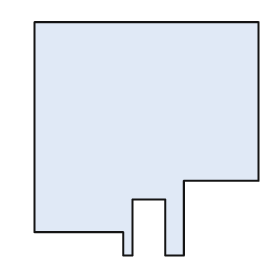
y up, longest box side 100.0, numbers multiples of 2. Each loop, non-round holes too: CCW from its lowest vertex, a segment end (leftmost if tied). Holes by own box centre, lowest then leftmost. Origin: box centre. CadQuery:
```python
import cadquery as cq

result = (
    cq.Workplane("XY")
    .moveTo(-10.0, -50.0)
    .lineTo(-6.0, -50.0)
    .lineTo(-6.0, -26.0)
    .lineTo(8.0, -26.0)
    .lineTo(8.0, -50.0)
    .lineTo(16.0, -50.0)
    .lineTo(16.0, -18.0)
    .lineTo(48.0, -18.0)
    .lineTo(48.0, 50.0)
    .lineTo(-48.0, 50.0)
    .lineTo(-48.0, -40.0)
    .lineTo(-10.0, -40.0)
    .close()
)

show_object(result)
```